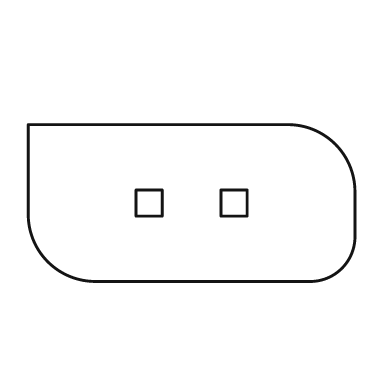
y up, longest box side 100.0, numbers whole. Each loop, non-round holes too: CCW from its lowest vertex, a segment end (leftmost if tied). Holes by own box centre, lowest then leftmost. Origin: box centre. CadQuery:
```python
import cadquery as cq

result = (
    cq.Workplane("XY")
    .moveTo(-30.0, -24.0)
    .lineTo(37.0, -24.0)
    .threePointArc((46.0, -20.0), (50.0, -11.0))
    .lineTo(50.0, 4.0)
    .threePointArc((44.0, 18.0), (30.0, 24.0))
    .lineTo(-50.0, 24.0)
    .lineTo(-50.0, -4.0)
    .threePointArc((-44.0, -18.0), (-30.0, -24.0))
    .close()
    .moveTo(-17.0, -4.0)
    .lineTo(-9.0, -4.0)
    .lineTo(-9.0, 4.0)
    .lineTo(-17.0, 4.0)
    .close()
    .moveTo(9.0, -4.0)
    .lineTo(17.0, -4.0)
    .lineTo(17.0, 4.0)
    .lineTo(9.0, 4.0)
    .close()
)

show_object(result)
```